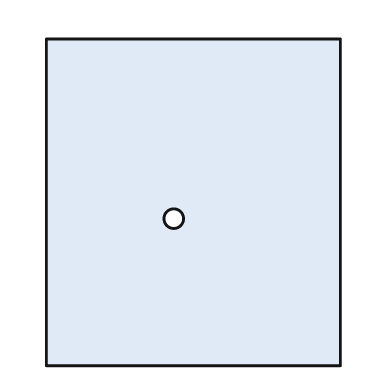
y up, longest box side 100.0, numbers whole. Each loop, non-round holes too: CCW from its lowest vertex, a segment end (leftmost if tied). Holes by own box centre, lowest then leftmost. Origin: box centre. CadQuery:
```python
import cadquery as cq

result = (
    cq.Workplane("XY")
    .moveTo(-45.0, -50.0)
    .lineTo(45.0, -50.0)
    .lineTo(45.0, 50.0)
    .lineTo(-45.0, 50.0)
    .close()
    .moveTo(-6.0, -5.0)
    .circle(3.0)
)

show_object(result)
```